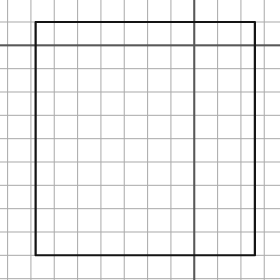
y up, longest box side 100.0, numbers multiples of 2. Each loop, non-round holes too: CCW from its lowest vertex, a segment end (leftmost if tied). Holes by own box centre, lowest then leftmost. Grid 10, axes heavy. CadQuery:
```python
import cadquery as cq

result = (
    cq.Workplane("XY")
    .moveTo(-68.0, -90.0)
    .lineTo(26.0, -90.0)
    .lineTo(26.0, 10.0)
    .lineTo(-68.0, 10.0)
    .close()
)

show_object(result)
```